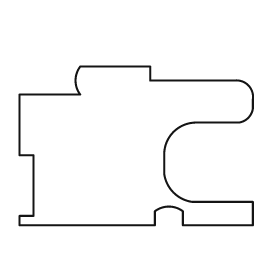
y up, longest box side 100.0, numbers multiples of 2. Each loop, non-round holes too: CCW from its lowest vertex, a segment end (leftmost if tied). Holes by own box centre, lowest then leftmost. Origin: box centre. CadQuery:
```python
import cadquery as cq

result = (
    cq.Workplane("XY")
    .moveTo(-50.0, -34.0)
    .lineTo(8.0, -34.0)
    .lineTo(8.0, -28.0)
    .threePointArc((14.0, -26.0), (20.0, -28.0))
    .lineTo(20.0, -34.0)
    .lineTo(50.0, -34.0)
    .lineTo(50.0, -24.0)
    .lineTo(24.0, -24.0)
    .threePointArc((16.0, -20.0), (12.0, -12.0))
    .lineTo(12.0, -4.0)
    .threePointArc((16.0, 6.0), (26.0, 10.0))
    .lineTo(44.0, 10.0)
    .threePointArc((48.0, 12.0), (50.0, 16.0))
    .lineTo(50.0, 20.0)
    .threePointArc((48.0, 26.0), (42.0, 28.0))
    .lineTo(6.0, 28.0)
    .lineTo(6.0, 34.0)
    .lineTo(-24.0, 34.0)
    .threePointArc((-26.0, 28.0), (-24.0, 22.0))
    .lineTo(-50.0, 22.0)
    .lineTo(-50.0, -4.0)
    .lineTo(-44.0, -4.0)
    .lineTo(-44.0, -30.0)
    .lineTo(-50.0, -30.0)
    .close()
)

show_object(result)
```